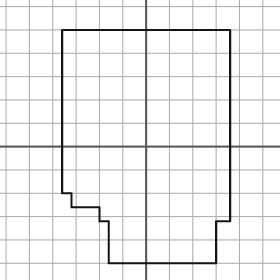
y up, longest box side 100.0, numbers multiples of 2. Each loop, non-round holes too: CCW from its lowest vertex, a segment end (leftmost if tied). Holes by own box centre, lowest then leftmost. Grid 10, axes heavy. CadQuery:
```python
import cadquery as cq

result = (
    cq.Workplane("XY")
    .moveTo(-16.0, -50.0)
    .lineTo(30.0, -50.0)
    .lineTo(30.0, -32.0)
    .lineTo(36.0, -32.0)
    .lineTo(36.0, 50.0)
    .lineTo(-36.0, 50.0)
    .lineTo(-36.0, -20.0)
    .lineTo(-32.0, -20.0)
    .lineTo(-32.0, -26.0)
    .lineTo(-20.0, -26.0)
    .lineTo(-20.0, -32.0)
    .lineTo(-16.0, -32.0)
    .close()
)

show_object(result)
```